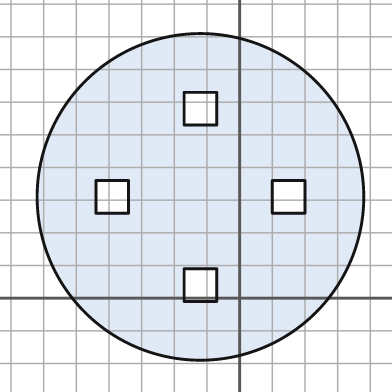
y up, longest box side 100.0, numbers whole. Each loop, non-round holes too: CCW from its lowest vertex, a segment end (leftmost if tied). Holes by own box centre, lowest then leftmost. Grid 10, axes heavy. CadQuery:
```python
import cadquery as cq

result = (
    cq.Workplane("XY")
    .moveTo(-12.0, 31.0)
    .circle(50.0)
    .moveTo(-17.0, -1.0)
    .lineTo(-7.0, -1.0)
    .lineTo(-7.0, 9.0)
    .lineTo(-17.0, 9.0)
    .close()
    .moveTo(-44.0, 26.0)
    .lineTo(-34.0, 26.0)
    .lineTo(-34.0, 36.0)
    .lineTo(-44.0, 36.0)
    .close()
    .moveTo(10.0, 26.0)
    .lineTo(20.0, 26.0)
    .lineTo(20.0, 36.0)
    .lineTo(10.0, 36.0)
    .close()
    .moveTo(-17.0, 53.0)
    .lineTo(-7.0, 53.0)
    .lineTo(-7.0, 63.0)
    .lineTo(-17.0, 63.0)
    .close()
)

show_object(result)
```